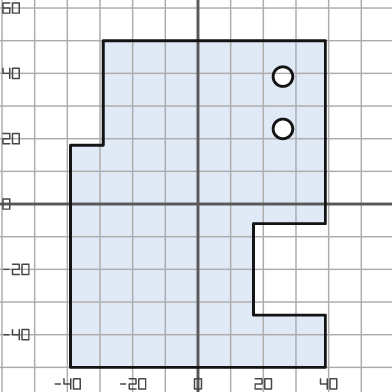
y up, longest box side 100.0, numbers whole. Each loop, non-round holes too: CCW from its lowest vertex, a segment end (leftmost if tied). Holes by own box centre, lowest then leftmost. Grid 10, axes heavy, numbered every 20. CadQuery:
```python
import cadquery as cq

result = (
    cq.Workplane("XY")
    .moveTo(-39.0, -50.0)
    .lineTo(39.0, -50.0)
    .lineTo(39.0, -34.0)
    .lineTo(17.0, -34.0)
    .lineTo(17.0, -6.0)
    .lineTo(39.0, -6.0)
    .lineTo(39.0, 50.0)
    .lineTo(-29.0, 50.0)
    .lineTo(-29.0, 18.0)
    .lineTo(-39.0, 18.0)
    .close()
    .moveTo(26.0, 23.0)
    .circle(3.0)
    .moveTo(26.0, 39.0)
    .circle(3.0)
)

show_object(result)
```